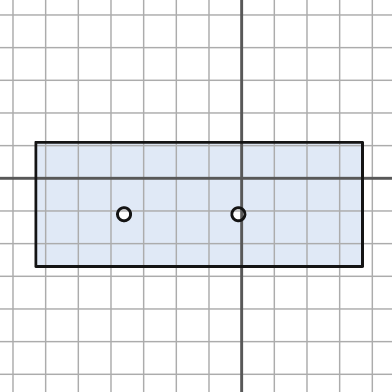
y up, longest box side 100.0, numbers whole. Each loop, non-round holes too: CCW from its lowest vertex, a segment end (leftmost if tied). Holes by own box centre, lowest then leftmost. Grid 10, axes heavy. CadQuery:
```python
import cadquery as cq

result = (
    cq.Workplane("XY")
    .moveTo(-63.0, -27.0)
    .lineTo(37.0, -27.0)
    .lineTo(37.0, 11.0)
    .lineTo(-63.0, 11.0)
    .close()
    .moveTo(-36.0, -11.0)
    .circle(2.0)
    .moveTo(-1.0, -11.0)
    .circle(2.0)
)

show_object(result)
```